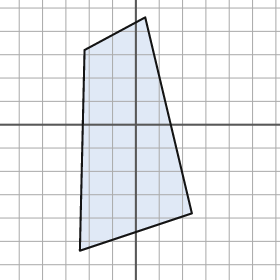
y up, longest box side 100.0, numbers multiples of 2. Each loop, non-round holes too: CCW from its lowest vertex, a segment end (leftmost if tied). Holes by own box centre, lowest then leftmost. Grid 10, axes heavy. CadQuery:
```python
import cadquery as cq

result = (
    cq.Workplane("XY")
    .moveTo(-24.0, -54.0)
    .lineTo(24.0, -38.0)
    .lineTo(4.0, 46.0)
    .lineTo(-22.0, 32.0)
    .close()
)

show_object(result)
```